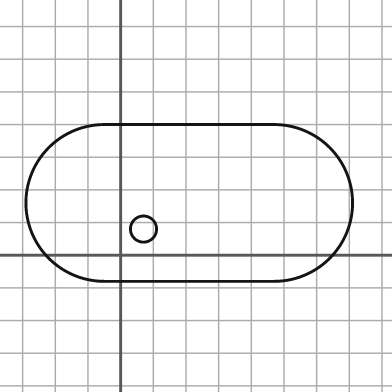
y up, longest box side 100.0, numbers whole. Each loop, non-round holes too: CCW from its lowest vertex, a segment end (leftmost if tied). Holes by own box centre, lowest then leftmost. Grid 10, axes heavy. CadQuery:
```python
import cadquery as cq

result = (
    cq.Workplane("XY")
    .moveTo(-5.0, -8.0)
    .lineTo(47.0, -8.0)
    .threePointArc((71.0, 16.0), (47.0, 40.0))
    .lineTo(-5.0, 40.0)
    .threePointArc((-29.0, 16.0), (-5.0, -8.0))
    .close()
    .moveTo(7.0, 8.0)
    .circle(4.0)
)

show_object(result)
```